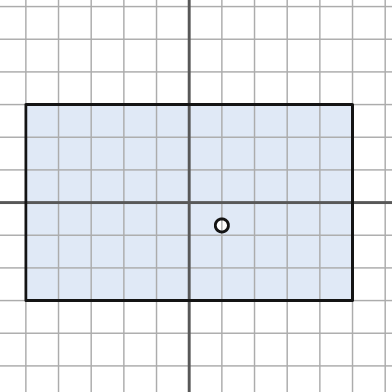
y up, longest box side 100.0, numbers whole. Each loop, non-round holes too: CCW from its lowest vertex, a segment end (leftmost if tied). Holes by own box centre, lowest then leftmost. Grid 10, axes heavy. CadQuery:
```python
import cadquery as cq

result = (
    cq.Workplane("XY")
    .moveTo(-50.0, -30.0)
    .lineTo(50.0, -30.0)
    .lineTo(50.0, 30.0)
    .lineTo(-50.0, 30.0)
    .close()
    .moveTo(10.0, -7.0)
    .circle(2.0)
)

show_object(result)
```